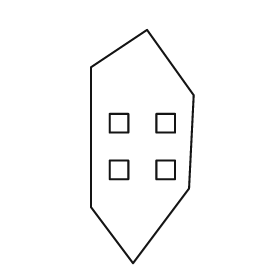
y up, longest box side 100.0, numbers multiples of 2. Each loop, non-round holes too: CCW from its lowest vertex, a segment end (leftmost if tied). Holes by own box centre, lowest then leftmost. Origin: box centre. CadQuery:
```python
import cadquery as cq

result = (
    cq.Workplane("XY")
    .moveTo(-4.0, -50.0)
    .lineTo(20.0, -18.0)
    .lineTo(22.0, 22.0)
    .lineTo(2.0, 50.0)
    .lineTo(-22.0, 34.0)
    .lineTo(-22.0, -26.0)
    .close()
    .moveTo(-14.0, -14.0)
    .lineTo(-6.0, -14.0)
    .lineTo(-6.0, -6.0)
    .lineTo(-14.0, -6.0)
    .close()
    .moveTo(6.0, -14.0)
    .lineTo(14.0, -14.0)
    .lineTo(14.0, -6.0)
    .lineTo(6.0, -6.0)
    .close()
    .moveTo(-14.0, 6.0)
    .lineTo(-6.0, 6.0)
    .lineTo(-6.0, 14.0)
    .lineTo(-14.0, 14.0)
    .close()
    .moveTo(6.0, 6.0)
    .lineTo(14.0, 6.0)
    .lineTo(14.0, 14.0)
    .lineTo(6.0, 14.0)
    .close()
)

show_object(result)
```